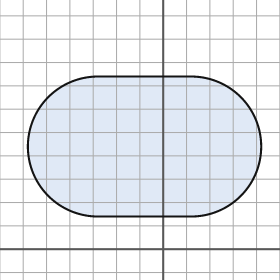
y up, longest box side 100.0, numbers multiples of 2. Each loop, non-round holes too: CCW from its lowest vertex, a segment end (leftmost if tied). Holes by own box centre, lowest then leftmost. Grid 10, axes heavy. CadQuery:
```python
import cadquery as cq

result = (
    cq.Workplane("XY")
    .moveTo(-28.0, 14.0)
    .lineTo(12.0, 14.0)
    .threePointArc((42.0, 44.0), (12.0, 74.0))
    .lineTo(-28.0, 74.0)
    .threePointArc((-58.0, 44.0), (-28.0, 14.0))
    .close()
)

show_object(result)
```